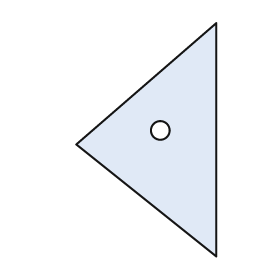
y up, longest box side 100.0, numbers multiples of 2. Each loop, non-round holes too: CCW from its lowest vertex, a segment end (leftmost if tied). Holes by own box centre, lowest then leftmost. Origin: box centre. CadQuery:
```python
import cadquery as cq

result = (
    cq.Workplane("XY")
    .moveTo(30.0, -50.0)
    .lineTo(30.0, 50.0)
    .lineTo(-30.0, -2.0)
    .close()
    .moveTo(6.0, 4.0)
    .circle(4.0)
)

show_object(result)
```